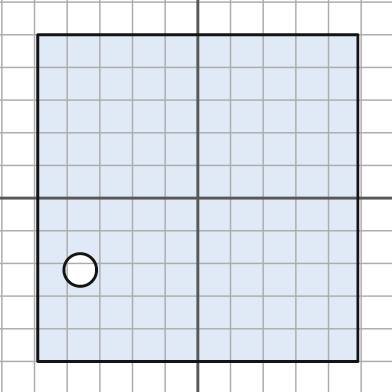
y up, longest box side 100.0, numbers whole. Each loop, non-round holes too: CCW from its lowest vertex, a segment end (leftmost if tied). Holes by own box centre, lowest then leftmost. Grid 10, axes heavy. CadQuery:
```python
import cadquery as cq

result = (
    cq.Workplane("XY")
    .moveTo(-49.0, -50.0)
    .lineTo(49.0, -50.0)
    .lineTo(49.0, 50.0)
    .lineTo(-49.0, 50.0)
    .close()
    .moveTo(-36.0, -22.0)
    .circle(5.0)
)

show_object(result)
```